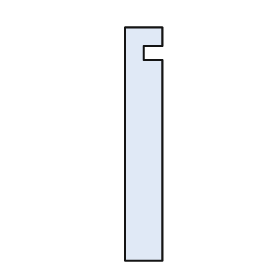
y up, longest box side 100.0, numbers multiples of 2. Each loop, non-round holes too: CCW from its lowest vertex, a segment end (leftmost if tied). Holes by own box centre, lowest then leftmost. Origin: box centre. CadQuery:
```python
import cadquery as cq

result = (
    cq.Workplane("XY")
    .moveTo(-8.0, -50.0)
    .lineTo(8.0, -50.0)
    .lineTo(8.0, 36.0)
    .lineTo(0.0, 36.0)
    .lineTo(0.0, 42.0)
    .lineTo(8.0, 42.0)
    .lineTo(8.0, 50.0)
    .lineTo(-8.0, 50.0)
    .close()
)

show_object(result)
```